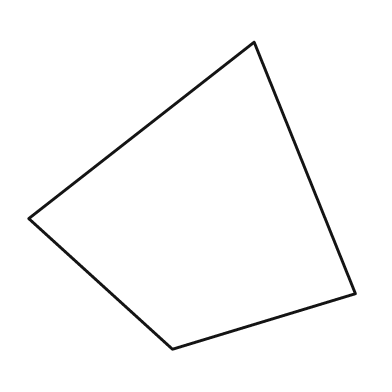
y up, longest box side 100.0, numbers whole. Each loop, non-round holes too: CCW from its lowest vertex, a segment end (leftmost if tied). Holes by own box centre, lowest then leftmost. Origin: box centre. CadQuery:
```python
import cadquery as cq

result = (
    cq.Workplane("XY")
    .moveTo(-6.0, -47.0)
    .lineTo(50.0, -30.0)
    .lineTo(19.0, 47.0)
    .lineTo(-50.0, -7.0)
    .close()
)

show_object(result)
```